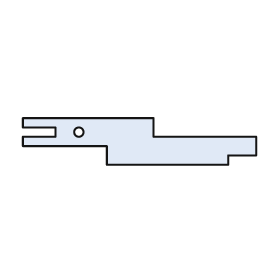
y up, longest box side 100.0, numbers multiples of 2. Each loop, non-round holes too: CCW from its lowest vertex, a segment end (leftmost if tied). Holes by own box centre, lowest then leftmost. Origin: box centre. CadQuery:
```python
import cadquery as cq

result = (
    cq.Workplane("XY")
    .moveTo(-14.0, -10.0)
    .lineTo(38.0, -10.0)
    .lineTo(38.0, -6.0)
    .lineTo(50.0, -6.0)
    .lineTo(50.0, 2.0)
    .lineTo(6.0, 2.0)
    .lineTo(6.0, 10.0)
    .lineTo(-50.0, 10.0)
    .lineTo(-50.0, 6.0)
    .lineTo(-36.0, 6.0)
    .lineTo(-36.0, 2.0)
    .lineTo(-50.0, 2.0)
    .lineTo(-50.0, -2.0)
    .lineTo(-14.0, -2.0)
    .close()
    .moveTo(-26.0, 4.0)
    .circle(2.0)
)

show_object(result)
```